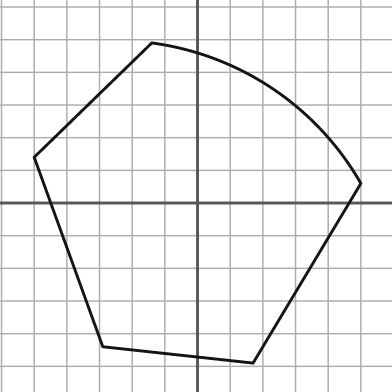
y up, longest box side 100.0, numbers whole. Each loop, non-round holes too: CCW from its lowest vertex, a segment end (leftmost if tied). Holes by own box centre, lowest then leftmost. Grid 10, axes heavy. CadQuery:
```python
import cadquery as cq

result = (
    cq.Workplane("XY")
    .moveTo(17.0, -49.0)
    .lineTo(50.0, 6.0)
    .threePointArc((23.0, 35.0), (-14.0, 49.0))
    .lineTo(-50.0, 14.0)
    .lineTo(-29.0, -44.0)
    .close()
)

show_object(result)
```